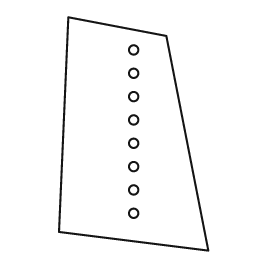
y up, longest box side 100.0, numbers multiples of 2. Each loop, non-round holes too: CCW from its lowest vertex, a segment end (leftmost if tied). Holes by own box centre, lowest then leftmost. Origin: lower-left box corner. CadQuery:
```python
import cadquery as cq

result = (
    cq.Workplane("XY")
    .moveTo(64.0, 0.0)
    .lineTo(46.0, 92.0)
    .lineTo(4.0, 100.0)
    .lineTo(0.0, 8.0)
    .close()
    .moveTo(32.0, 16.0)
    .circle(2.0)
    .moveTo(32.0, 26.0)
    .circle(2.0)
    .moveTo(32.0, 36.0)
    .circle(2.0)
    .moveTo(32.0, 46.0)
    .circle(2.0)
    .moveTo(32.0, 56.0)
    .circle(2.0)
    .moveTo(32.0, 66.0)
    .circle(2.0)
    .moveTo(32.0, 76.0)
    .circle(2.0)
    .moveTo(32.0, 86.0)
    .circle(2.0)
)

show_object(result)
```